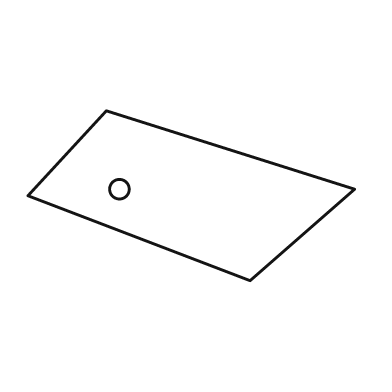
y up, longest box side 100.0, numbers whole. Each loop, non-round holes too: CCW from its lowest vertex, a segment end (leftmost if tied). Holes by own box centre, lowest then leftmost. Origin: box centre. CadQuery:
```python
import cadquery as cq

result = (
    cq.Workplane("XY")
    .moveTo(18.0, -26.0)
    .lineTo(50.0, 2.0)
    .lineTo(-26.0, 26.0)
    .lineTo(-50.0, 0.0)
    .close()
    .moveTo(-22.0, 2.0)
    .circle(3.0)
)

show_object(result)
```